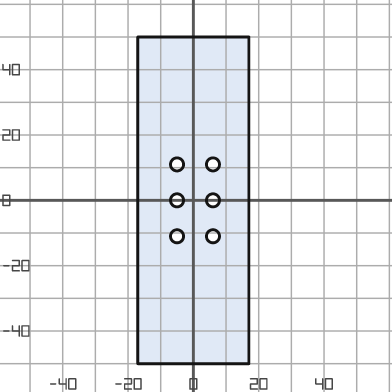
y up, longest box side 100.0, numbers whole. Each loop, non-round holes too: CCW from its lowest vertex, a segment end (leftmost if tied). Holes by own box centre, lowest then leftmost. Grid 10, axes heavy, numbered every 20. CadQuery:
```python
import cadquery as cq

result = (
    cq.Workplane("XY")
    .moveTo(-17.0, -50.0)
    .lineTo(17.0, -50.0)
    .lineTo(17.0, 50.0)
    .lineTo(-17.0, 50.0)
    .close()
    .moveTo(-5.0, -11.0)
    .circle(2.0)
    .moveTo(6.0, -11.0)
    .circle(2.0)
    .moveTo(-5.0, 0.0)
    .circle(2.0)
    .moveTo(6.0, 0.0)
    .circle(2.0)
    .moveTo(-5.0, 11.0)
    .circle(2.0)
    .moveTo(6.0, 11.0)
    .circle(2.0)
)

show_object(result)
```